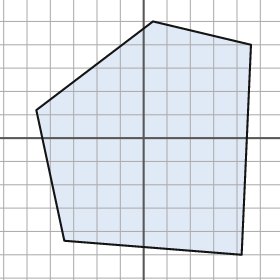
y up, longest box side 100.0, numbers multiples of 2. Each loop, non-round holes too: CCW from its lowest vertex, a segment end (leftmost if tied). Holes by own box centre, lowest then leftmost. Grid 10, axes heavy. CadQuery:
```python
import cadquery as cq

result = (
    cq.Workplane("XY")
    .moveTo(42.0, -50.0)
    .lineTo(46.0, 40.0)
    .lineTo(4.0, 50.0)
    .lineTo(-46.0, 12.0)
    .lineTo(-34.0, -44.0)
    .close()
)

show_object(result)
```